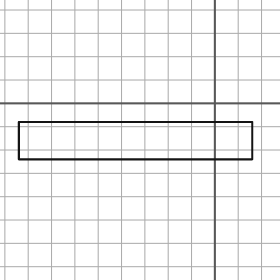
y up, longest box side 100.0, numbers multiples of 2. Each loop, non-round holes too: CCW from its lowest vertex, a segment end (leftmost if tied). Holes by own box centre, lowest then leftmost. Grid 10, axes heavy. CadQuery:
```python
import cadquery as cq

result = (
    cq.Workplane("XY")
    .moveTo(-84.0, -24.0)
    .lineTo(16.0, -24.0)
    .lineTo(16.0, -8.0)
    .lineTo(-84.0, -8.0)
    .close()
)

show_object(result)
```